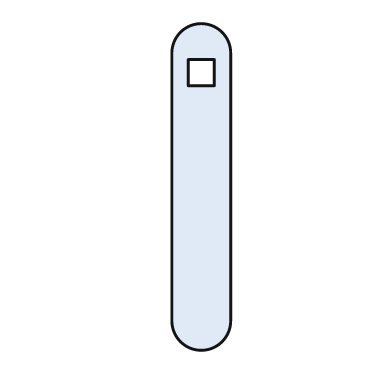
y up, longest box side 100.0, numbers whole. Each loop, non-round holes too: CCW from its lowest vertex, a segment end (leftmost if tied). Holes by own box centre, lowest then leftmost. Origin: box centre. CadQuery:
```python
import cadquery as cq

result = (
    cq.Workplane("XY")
    .moveTo(-9.0, -41.0)
    .threePointArc((0.0, -50.0), (9.0, -41.0))
    .lineTo(9.0, 41.0)
    .threePointArc((0.0, 50.0), (-9.0, 41.0))
    .close()
    .moveTo(-4.0, 31.0)
    .lineTo(4.0, 31.0)
    .lineTo(4.0, 39.0)
    .lineTo(-4.0, 39.0)
    .close()
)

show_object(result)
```